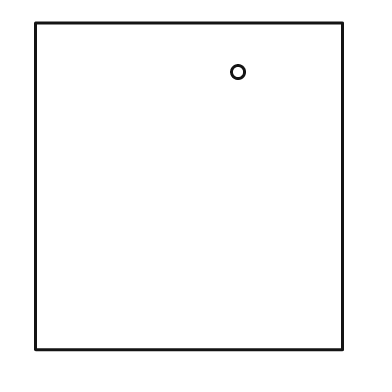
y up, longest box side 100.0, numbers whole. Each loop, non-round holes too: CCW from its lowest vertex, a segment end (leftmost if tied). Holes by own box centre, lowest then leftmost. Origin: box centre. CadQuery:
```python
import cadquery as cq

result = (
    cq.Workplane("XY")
    .moveTo(-47.0, -50.0)
    .lineTo(47.0, -50.0)
    .lineTo(47.0, 50.0)
    .lineTo(-47.0, 50.0)
    .close()
    .moveTo(15.0, 35.0)
    .circle(2.0)
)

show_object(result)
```